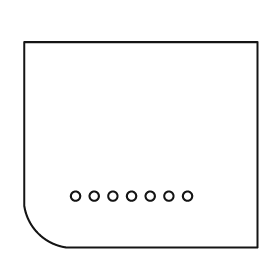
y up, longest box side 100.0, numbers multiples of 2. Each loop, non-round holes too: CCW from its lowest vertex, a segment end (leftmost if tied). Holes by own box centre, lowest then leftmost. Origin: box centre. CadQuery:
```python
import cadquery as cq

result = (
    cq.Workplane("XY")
    .moveTo(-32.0, -44.0)
    .lineTo(50.0, -44.0)
    .lineTo(50.0, 44.0)
    .lineTo(-50.0, 44.0)
    .lineTo(-50.0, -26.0)
    .threePointArc((-44.0, -38.0), (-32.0, -44.0))
    .close()
    .moveTo(-28.0, -22.0)
    .circle(2.0)
    .moveTo(-20.0, -22.0)
    .circle(2.0)
    .moveTo(-12.0, -22.0)
    .circle(2.0)
    .moveTo(-4.0, -22.0)
    .circle(2.0)
    .moveTo(4.0, -22.0)
    .circle(2.0)
    .moveTo(12.0, -22.0)
    .circle(2.0)
    .moveTo(20.0, -22.0)
    .circle(2.0)
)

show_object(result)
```